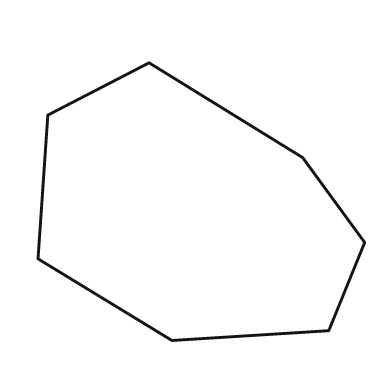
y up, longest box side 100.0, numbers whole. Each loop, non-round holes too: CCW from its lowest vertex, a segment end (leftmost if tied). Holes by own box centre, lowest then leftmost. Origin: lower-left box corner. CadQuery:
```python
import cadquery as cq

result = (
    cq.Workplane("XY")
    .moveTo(41.0, 0.0)
    .lineTo(89.0, 3.0)
    .lineTo(100.0, 30.0)
    .lineTo(81.0, 56.0)
    .lineTo(34.0, 85.0)
    .lineTo(3.0, 69.0)
    .lineTo(0.0, 25.0)
    .close()
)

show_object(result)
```